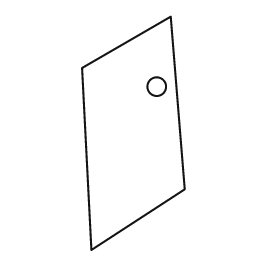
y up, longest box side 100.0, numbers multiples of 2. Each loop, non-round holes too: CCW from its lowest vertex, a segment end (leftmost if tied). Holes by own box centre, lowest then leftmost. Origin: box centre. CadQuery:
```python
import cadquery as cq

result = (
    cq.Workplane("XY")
    .moveTo(-18.0, -50.0)
    .lineTo(22.0, -24.0)
    .lineTo(16.0, 50.0)
    .lineTo(-22.0, 28.0)
    .close()
    .moveTo(10.0, 20.0)
    .circle(4.0)
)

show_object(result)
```